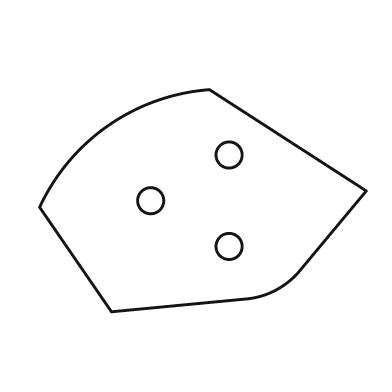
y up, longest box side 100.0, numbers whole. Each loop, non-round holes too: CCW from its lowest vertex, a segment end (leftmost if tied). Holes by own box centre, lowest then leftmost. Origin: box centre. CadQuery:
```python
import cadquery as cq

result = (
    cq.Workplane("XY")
    .moveTo(-28.0, -34.0)
    .lineTo(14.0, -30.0)
    .threePointArc((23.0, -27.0), (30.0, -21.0))
    .lineTo(50.0, 3.0)
    .lineTo(2.0, 34.0)
    .threePointArc((-29.0, 23.0), (-50.0, -2.0))
    .close()
    .moveTo(8.0, -14.0)
    .circle(4.0)
    .moveTo(-16.0, 0.0)
    .circle(4.0)
    .moveTo(8.0, 14.0)
    .circle(4.0)
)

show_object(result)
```